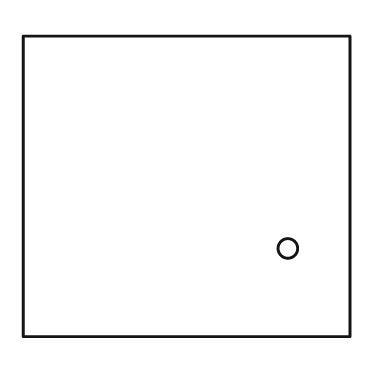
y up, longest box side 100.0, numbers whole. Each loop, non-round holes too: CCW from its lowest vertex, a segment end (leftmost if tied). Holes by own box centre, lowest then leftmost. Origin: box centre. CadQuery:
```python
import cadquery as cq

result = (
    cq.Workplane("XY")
    .moveTo(-50.0, -46.0)
    .lineTo(50.0, -46.0)
    .lineTo(50.0, 46.0)
    .lineTo(-50.0, 46.0)
    .close()
    .moveTo(31.0, -19.0)
    .circle(3.0)
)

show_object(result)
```